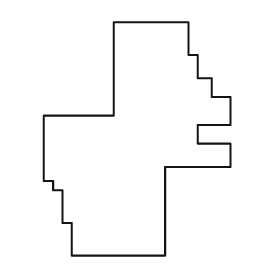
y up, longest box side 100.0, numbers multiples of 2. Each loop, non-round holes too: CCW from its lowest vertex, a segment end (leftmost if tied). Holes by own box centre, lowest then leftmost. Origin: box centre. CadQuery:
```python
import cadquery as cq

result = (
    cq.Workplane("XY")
    .moveTo(-28.0, -50.0)
    .lineTo(12.0, -50.0)
    .lineTo(12.0, -12.0)
    .lineTo(40.0, -12.0)
    .lineTo(40.0, -2.0)
    .lineTo(26.0, -2.0)
    .lineTo(26.0, 6.0)
    .lineTo(40.0, 6.0)
    .lineTo(40.0, 18.0)
    .lineTo(32.0, 18.0)
    .lineTo(32.0, 26.0)
    .lineTo(26.0, 26.0)
    .lineTo(26.0, 36.0)
    .lineTo(22.0, 36.0)
    .lineTo(22.0, 50.0)
    .lineTo(-10.0, 50.0)
    .lineTo(-10.0, 10.0)
    .lineTo(-40.0, 10.0)
    .lineTo(-40.0, -18.0)
    .lineTo(-36.0, -18.0)
    .lineTo(-36.0, -22.0)
    .lineTo(-32.0, -22.0)
    .lineTo(-32.0, -36.0)
    .lineTo(-28.0, -36.0)
    .close()
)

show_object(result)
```